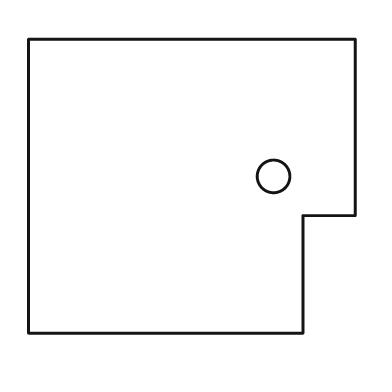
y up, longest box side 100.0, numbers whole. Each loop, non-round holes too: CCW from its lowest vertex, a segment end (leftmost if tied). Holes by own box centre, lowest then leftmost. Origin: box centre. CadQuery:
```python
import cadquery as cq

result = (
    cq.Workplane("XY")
    .moveTo(-50.0, -45.0)
    .lineTo(34.0, -45.0)
    .lineTo(34.0, -9.0)
    .lineTo(50.0, -9.0)
    .lineTo(50.0, 45.0)
    .lineTo(-50.0, 45.0)
    .close()
    .moveTo(25.0, 3.0)
    .circle(5.0)
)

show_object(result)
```